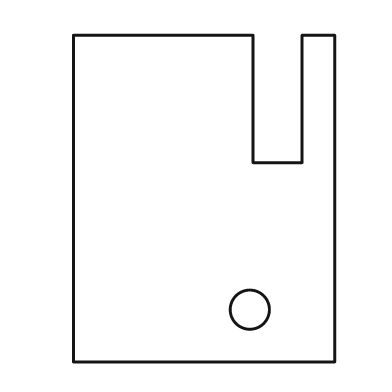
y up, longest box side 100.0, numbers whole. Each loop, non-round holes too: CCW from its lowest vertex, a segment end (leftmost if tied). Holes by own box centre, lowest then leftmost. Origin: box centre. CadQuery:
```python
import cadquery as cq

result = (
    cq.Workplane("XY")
    .moveTo(-40.0, -50.0)
    .lineTo(40.0, -50.0)
    .lineTo(40.0, 50.0)
    .lineTo(30.0, 50.0)
    .lineTo(30.0, 11.0)
    .lineTo(15.0, 11.0)
    .lineTo(15.0, 50.0)
    .lineTo(-40.0, 50.0)
    .close()
    .moveTo(14.0, -34.0)
    .circle(6.0)
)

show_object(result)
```